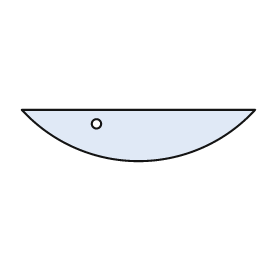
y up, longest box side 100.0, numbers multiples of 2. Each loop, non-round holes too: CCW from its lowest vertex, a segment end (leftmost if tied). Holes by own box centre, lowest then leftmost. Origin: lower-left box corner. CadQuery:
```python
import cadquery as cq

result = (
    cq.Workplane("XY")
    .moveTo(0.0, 22.0)
    .threePointArc((50.0, 0.0), (100.0, 22.0))
    .close()
    .moveTo(32.0, 16.0)
    .circle(2.0)
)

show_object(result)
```